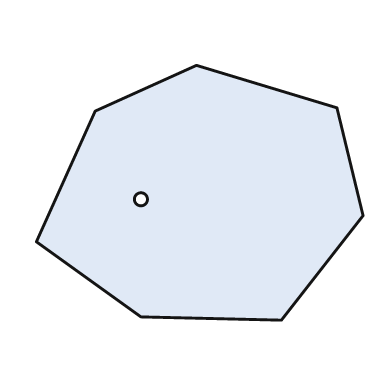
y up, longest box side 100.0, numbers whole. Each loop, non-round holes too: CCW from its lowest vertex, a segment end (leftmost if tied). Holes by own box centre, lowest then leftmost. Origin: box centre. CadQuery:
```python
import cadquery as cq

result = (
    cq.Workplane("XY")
    .moveTo(25.0, -39.0)
    .lineTo(50.0, -7.0)
    .lineTo(42.0, 26.0)
    .lineTo(-1.0, 39.0)
    .lineTo(-32.0, 25.0)
    .lineTo(-50.0, -15.0)
    .lineTo(-18.0, -38.0)
    .close()
    .moveTo(-18.0, -2.0)
    .circle(2.0)
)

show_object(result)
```